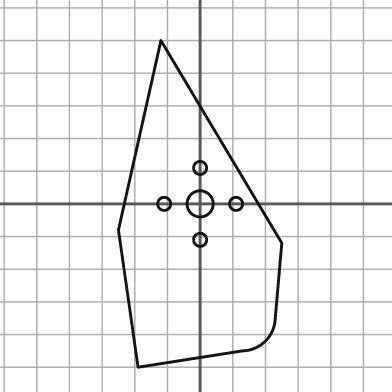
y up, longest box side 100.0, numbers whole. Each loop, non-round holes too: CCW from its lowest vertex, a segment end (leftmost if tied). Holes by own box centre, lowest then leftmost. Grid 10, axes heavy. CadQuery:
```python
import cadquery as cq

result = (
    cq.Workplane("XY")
    .moveTo(-19.0, -50.0)
    .lineTo(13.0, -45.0)
    .threePointArc((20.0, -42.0), (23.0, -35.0))
    .lineTo(25.0, -12.0)
    .lineTo(-12.0, 50.0)
    .lineTo(-25.0, -8.0)
    .close()
    .moveTo(0.0, -11.0)
    .circle(2.0)
    .moveTo(-11.0, 0.0)
    .circle(2.0)
    .moveTo(0.0, 0.0)
    .circle(4.0)
    .moveTo(11.0, 0.0)
    .circle(2.0)
    .moveTo(0.0, 11.0)
    .circle(2.0)
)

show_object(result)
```